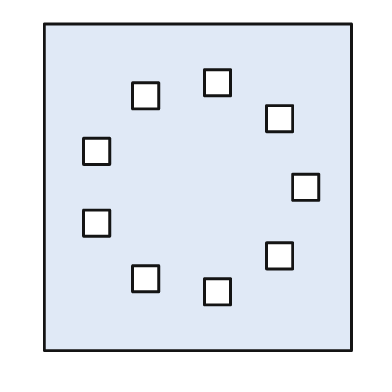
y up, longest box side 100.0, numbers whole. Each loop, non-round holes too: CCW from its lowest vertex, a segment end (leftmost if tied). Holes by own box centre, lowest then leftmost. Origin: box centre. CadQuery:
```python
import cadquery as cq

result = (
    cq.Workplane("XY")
    .moveTo(-47.0, -50.0)
    .lineTo(47.0, -50.0)
    .lineTo(47.0, 50.0)
    .lineTo(-47.0, 50.0)
    .close()
    .moveTo(2.0, -36.0)
    .lineTo(10.0, -36.0)
    .lineTo(10.0, -28.0)
    .lineTo(2.0, -28.0)
    .close()
    .moveTo(-20.0, -32.0)
    .lineTo(-12.0, -32.0)
    .lineTo(-12.0, -24.0)
    .lineTo(-20.0, -24.0)
    .close()
    .moveTo(21.0, -25.0)
    .lineTo(29.0, -25.0)
    .lineTo(29.0, -17.0)
    .lineTo(21.0, -17.0)
    .close()
    .moveTo(-35.0, -15.0)
    .lineTo(-27.0, -15.0)
    .lineTo(-27.0, -7.0)
    .lineTo(-35.0, -7.0)
    .close()
    .moveTo(29.0, -4.0)
    .lineTo(37.0, -4.0)
    .lineTo(37.0, 4.0)
    .lineTo(29.0, 4.0)
    .close()
    .moveTo(-35.0, 7.0)
    .lineTo(-27.0, 7.0)
    .lineTo(-27.0, 15.0)
    .lineTo(-35.0, 15.0)
    .close()
    .moveTo(21.0, 17.0)
    .lineTo(29.0, 17.0)
    .lineTo(29.0, 25.0)
    .lineTo(21.0, 25.0)
    .close()
    .moveTo(-20.0, 24.0)
    .lineTo(-12.0, 24.0)
    .lineTo(-12.0, 32.0)
    .lineTo(-20.0, 32.0)
    .close()
    .moveTo(2.0, 28.0)
    .lineTo(10.0, 28.0)
    .lineTo(10.0, 36.0)
    .lineTo(2.0, 36.0)
    .close()
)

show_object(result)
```